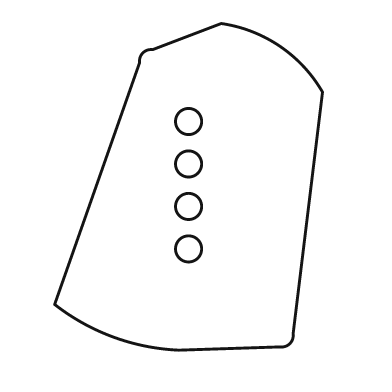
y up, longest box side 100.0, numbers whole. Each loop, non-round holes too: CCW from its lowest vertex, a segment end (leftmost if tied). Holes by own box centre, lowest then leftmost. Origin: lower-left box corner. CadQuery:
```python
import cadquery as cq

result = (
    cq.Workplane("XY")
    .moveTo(38.0, 0.0)
    .lineTo(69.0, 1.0)
    .threePointArc((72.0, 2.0), (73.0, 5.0))
    .lineTo(82.0, 79.0)
    .threePointArc((69.0, 93.0), (51.0, 100.0))
    .lineTo(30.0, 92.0)
    .threePointArc((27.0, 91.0), (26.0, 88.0))
    .lineTo(0.0, 14.0)
    .threePointArc((18.0, 4.0), (38.0, 0.0))
    .close()
    .moveTo(41.0, 31.0)
    .circle(4.0)
    .moveTo(41.0, 44.0)
    .circle(4.0)
    .moveTo(41.0, 57.0)
    .circle(4.0)
    .moveTo(41.0, 70.0)
    .circle(4.0)
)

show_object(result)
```